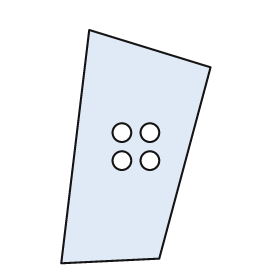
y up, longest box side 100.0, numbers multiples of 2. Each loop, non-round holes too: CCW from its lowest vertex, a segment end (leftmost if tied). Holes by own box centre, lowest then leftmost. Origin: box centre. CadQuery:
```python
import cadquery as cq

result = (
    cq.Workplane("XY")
    .moveTo(-32.0, -50.0)
    .lineTo(10.0, -48.0)
    .lineTo(32.0, 34.0)
    .lineTo(-20.0, 50.0)
    .close()
    .moveTo(-6.0, -6.0)
    .circle(4.0)
    .moveTo(6.0, -6.0)
    .circle(4.0)
    .moveTo(-6.0, 6.0)
    .circle(4.0)
    .moveTo(6.0, 6.0)
    .circle(4.0)
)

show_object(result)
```